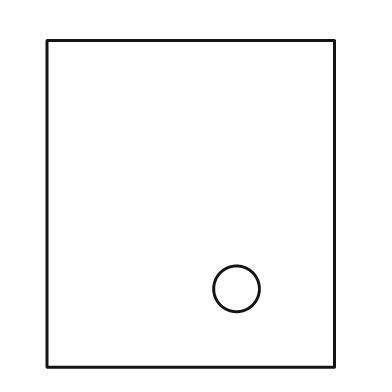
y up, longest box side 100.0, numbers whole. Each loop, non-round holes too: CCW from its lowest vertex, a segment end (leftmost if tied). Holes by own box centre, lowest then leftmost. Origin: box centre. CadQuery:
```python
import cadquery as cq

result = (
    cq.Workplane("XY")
    .moveTo(-44.0, -50.0)
    .lineTo(44.0, -50.0)
    .lineTo(44.0, 50.0)
    .lineTo(-44.0, 50.0)
    .close()
    .moveTo(14.0, -26.0)
    .circle(7.0)
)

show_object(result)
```